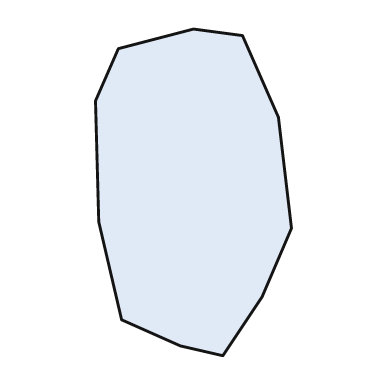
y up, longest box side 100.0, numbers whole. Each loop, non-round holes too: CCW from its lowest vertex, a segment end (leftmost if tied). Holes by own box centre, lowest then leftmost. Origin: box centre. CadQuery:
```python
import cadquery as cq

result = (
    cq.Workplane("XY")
    .moveTo(9.0, -50.0)
    .lineTo(21.0, -32.0)
    .lineTo(30.0, -11.0)
    .lineTo(26.0, 23.0)
    .lineTo(15.0, 48.0)
    .lineTo(0.0, 50.0)
    .lineTo(-23.0, 44.0)
    .lineTo(-30.0, 28.0)
    .lineTo(-29.0, -9.0)
    .lineTo(-22.0, -39.0)
    .lineTo(-4.0, -47.0)
    .close()
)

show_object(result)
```